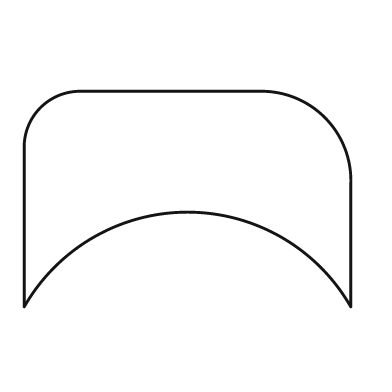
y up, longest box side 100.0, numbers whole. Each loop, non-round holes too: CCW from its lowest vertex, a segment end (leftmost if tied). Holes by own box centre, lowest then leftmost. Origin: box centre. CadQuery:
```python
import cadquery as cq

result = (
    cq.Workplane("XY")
    .moveTo(-50.0, -33.0)
    .threePointArc((0.0, -4.0), (50.0, -33.0))
    .lineTo(50.0, 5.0)
    .threePointArc((42.0, 25.0), (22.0, 33.0))
    .lineTo(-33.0, 33.0)
    .threePointArc((-45.0, 28.0), (-50.0, 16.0))
    .close()
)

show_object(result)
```